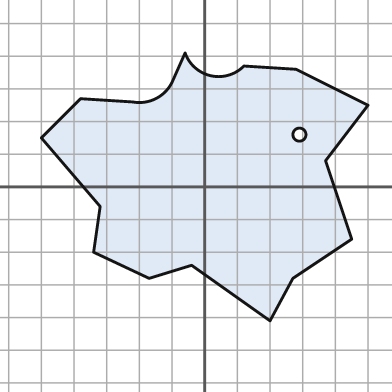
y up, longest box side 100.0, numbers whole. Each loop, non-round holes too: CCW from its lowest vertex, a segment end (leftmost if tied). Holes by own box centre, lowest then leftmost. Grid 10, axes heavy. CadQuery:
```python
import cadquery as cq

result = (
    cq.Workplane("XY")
    .moveTo(20.0, -41.0)
    .lineTo(27.0, -28.0)
    .lineTo(45.0, -16.0)
    .lineTo(37.0, 8.0)
    .lineTo(50.0, 25.0)
    .lineTo(28.0, 36.0)
    .lineTo(12.0, 37.0)
    .threePointArc((2.0, 34.0), (-6.0, 41.0))
    .lineTo(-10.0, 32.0)
    .threePointArc((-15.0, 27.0), (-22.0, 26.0))
    .lineTo(-38.0, 27.0)
    .lineTo(-50.0, 15.0)
    .lineTo(-32.0, -6.0)
    .lineTo(-34.0, -20.0)
    .lineTo(-17.0, -28.0)
    .lineTo(-4.0, -24.0)
    .close()
    .moveTo(29.0, 16.0)
    .circle(2.0)
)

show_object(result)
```